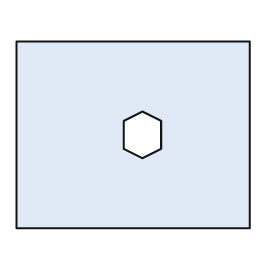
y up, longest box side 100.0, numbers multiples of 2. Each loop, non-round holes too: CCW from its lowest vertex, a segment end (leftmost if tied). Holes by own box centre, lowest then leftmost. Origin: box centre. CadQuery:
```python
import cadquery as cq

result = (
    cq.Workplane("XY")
    .moveTo(-50.0, -40.0)
    .lineTo(50.0, -40.0)
    .lineTo(50.0, 40.0)
    .lineTo(-50.0, 40.0)
    .close()
    .moveTo(4.0, -10.0)
    .lineTo(12.0, -6.0)
    .lineTo(12.0, 6.0)
    .lineTo(4.0, 10.0)
    .lineTo(-4.0, 6.0)
    .lineTo(-4.0, -6.0)
    .close()
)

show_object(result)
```